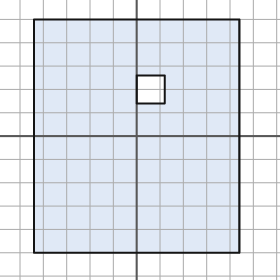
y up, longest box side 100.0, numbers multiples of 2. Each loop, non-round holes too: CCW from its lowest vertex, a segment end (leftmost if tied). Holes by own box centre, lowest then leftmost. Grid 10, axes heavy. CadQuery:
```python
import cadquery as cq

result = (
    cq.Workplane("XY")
    .moveTo(-44.0, -50.0)
    .lineTo(44.0, -50.0)
    .lineTo(44.0, 50.0)
    .lineTo(-44.0, 50.0)
    .close()
    .moveTo(0.0, 14.0)
    .lineTo(12.0, 14.0)
    .lineTo(12.0, 26.0)
    .lineTo(0.0, 26.0)
    .close()
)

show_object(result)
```